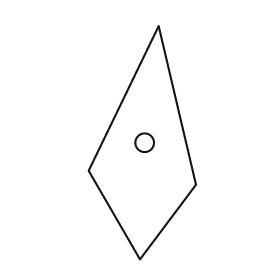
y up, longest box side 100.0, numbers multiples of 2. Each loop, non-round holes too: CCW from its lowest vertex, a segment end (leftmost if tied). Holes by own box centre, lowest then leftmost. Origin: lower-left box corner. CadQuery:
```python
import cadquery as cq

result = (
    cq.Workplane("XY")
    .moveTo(22.0, 0.0)
    .lineTo(46.0, 32.0)
    .lineTo(30.0, 100.0)
    .lineTo(0.0, 38.0)
    .close()
    .moveTo(24.0, 50.0)
    .circle(4.0)
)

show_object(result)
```